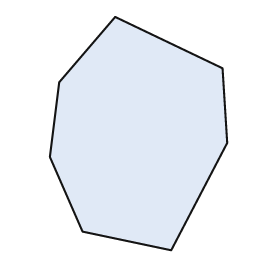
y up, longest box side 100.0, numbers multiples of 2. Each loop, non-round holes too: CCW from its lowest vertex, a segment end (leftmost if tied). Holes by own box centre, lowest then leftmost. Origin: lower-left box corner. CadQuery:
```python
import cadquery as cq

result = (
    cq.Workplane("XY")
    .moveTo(52.0, 0.0)
    .lineTo(76.0, 46.0)
    .lineTo(74.0, 78.0)
    .lineTo(28.0, 100.0)
    .lineTo(4.0, 72.0)
    .lineTo(0.0, 40.0)
    .lineTo(14.0, 8.0)
    .close()
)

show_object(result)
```